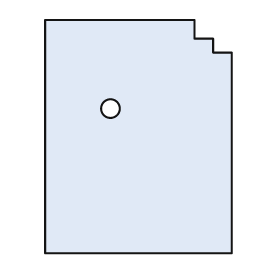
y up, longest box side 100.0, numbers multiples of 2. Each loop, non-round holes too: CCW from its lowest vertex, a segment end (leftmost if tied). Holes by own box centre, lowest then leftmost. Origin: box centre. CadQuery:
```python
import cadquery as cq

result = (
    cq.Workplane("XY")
    .moveTo(-40.0, -50.0)
    .lineTo(40.0, -50.0)
    .lineTo(40.0, 36.0)
    .lineTo(32.0, 36.0)
    .lineTo(32.0, 42.0)
    .lineTo(24.0, 42.0)
    .lineTo(24.0, 50.0)
    .lineTo(-40.0, 50.0)
    .close()
    .moveTo(-12.0, 12.0)
    .circle(4.0)
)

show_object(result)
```